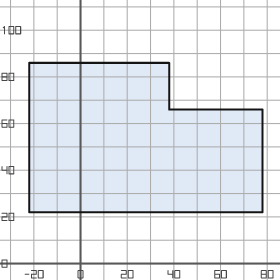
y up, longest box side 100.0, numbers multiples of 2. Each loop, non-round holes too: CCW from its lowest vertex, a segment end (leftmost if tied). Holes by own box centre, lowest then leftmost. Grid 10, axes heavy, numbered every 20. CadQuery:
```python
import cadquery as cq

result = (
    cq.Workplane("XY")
    .moveTo(-22.0, 22.0)
    .lineTo(78.0, 22.0)
    .lineTo(78.0, 66.0)
    .lineTo(38.0, 66.0)
    .lineTo(38.0, 86.0)
    .lineTo(-22.0, 86.0)
    .close()
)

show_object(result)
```